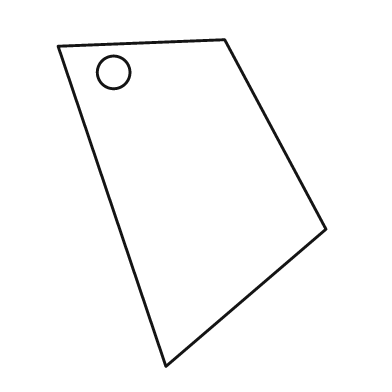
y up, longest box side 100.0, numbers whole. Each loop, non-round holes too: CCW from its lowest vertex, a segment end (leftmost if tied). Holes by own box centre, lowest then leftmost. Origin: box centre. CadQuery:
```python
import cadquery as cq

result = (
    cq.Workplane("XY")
    .moveTo(-8.0, -50.0)
    .lineTo(41.0, -8.0)
    .lineTo(10.0, 50.0)
    .lineTo(-41.0, 48.0)
    .close()
    .moveTo(-24.0, 40.0)
    .circle(5.0)
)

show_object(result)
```